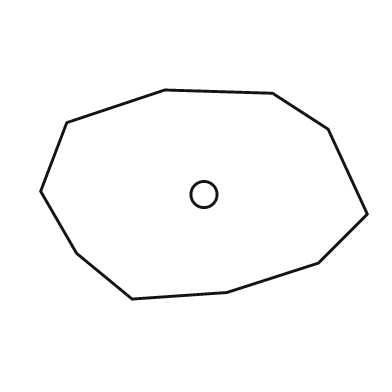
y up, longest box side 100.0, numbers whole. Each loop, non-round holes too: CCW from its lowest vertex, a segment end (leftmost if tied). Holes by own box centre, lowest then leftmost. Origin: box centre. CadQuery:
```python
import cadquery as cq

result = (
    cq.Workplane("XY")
    .moveTo(-22.0, -32.0)
    .lineTo(7.0, -30.0)
    .lineTo(35.0, -21.0)
    .lineTo(50.0, -6.0)
    .lineTo(38.0, 20.0)
    .lineTo(21.0, 31.0)
    .lineTo(-12.0, 32.0)
    .lineTo(-42.0, 22.0)
    .lineTo(-50.0, 1.0)
    .lineTo(-39.0, -18.0)
    .close()
    .moveTo(0.0, 0.0)
    .circle(4.0)
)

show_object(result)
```